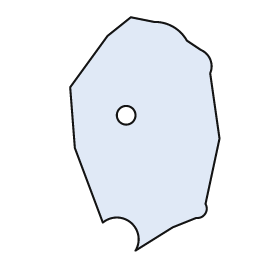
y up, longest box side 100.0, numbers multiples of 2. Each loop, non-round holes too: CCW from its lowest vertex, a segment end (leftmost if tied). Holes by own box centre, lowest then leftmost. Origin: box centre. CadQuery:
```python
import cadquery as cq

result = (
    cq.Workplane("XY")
    .moveTo(-4.0, -50.0)
    .lineTo(12.0, -40.0)
    .lineTo(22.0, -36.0)
    .threePointArc((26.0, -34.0), (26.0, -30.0))
    .lineTo(32.0, -2.0)
    .lineTo(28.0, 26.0)
    .threePointArc((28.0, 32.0), (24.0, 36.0))
    .lineTo(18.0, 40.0)
    .threePointArc((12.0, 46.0), (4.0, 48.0))
    .lineTo(-6.0, 50.0)
    .lineTo(-16.0, 42.0)
    .lineTo(-32.0, 20.0)
    .lineTo(-30.0, -6.0)
    .lineTo(-18.0, -38.0)
    .threePointArc((-6.0, -38.0), (-4.0, -50.0))
    .close()
    .moveTo(-8.0, 8.0)
    .circle(4.0)
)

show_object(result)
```